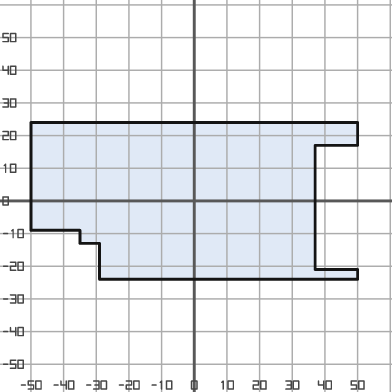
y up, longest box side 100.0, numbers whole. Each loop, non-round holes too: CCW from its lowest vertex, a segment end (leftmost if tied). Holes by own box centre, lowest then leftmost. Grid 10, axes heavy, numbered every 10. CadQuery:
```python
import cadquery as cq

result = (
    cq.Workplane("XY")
    .moveTo(-29.0, -24.0)
    .lineTo(50.0, -24.0)
    .lineTo(50.0, -21.0)
    .lineTo(37.0, -21.0)
    .lineTo(37.0, 17.0)
    .lineTo(50.0, 17.0)
    .lineTo(50.0, 24.0)
    .lineTo(-50.0, 24.0)
    .lineTo(-50.0, -9.0)
    .lineTo(-35.0, -9.0)
    .lineTo(-35.0, -13.0)
    .lineTo(-29.0, -13.0)
    .close()
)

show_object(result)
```